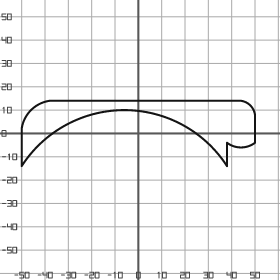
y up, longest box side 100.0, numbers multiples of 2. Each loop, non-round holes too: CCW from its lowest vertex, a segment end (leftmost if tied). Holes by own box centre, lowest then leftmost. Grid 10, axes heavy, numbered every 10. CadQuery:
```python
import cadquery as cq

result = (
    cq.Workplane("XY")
    .moveTo(-50.0, -14.0)
    .threePointArc((-6.0, 10.0), (38.0, -14.0))
    .lineTo(38.0, -4.0)
    .threePointArc((44.0, -6.0), (50.0, -4.0))
    .lineTo(50.0, 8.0)
    .threePointArc((48.0, 12.0), (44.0, 14.0))
    .lineTo(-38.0, 14.0)
    .threePointArc((-46.0, 10.0), (-50.0, 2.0))
    .close()
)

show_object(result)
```